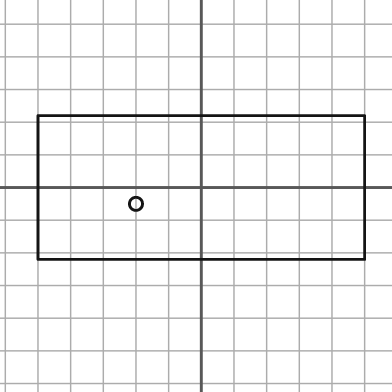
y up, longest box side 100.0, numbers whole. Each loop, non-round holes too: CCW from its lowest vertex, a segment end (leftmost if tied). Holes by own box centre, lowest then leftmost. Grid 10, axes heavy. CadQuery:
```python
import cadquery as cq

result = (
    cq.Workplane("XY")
    .moveTo(-50.0, -22.0)
    .lineTo(50.0, -22.0)
    .lineTo(50.0, 22.0)
    .lineTo(-50.0, 22.0)
    .close()
    .moveTo(-20.0, -5.0)
    .circle(2.0)
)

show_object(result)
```